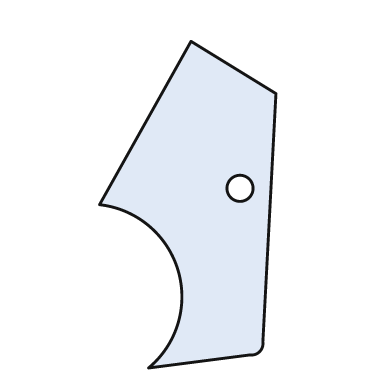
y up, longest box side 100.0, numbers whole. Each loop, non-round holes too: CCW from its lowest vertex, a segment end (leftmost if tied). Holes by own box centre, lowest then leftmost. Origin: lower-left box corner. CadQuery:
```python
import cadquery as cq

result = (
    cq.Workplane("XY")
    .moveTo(15.0, 0.0)
    .lineTo(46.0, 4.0)
    .threePointArc((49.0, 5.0), (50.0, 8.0))
    .lineTo(54.0, 84.0)
    .lineTo(28.0, 100.0)
    .lineTo(0.0, 50.0)
    .threePointArc((24.0, 30.0), (15.0, 0.0))
    .close()
    .moveTo(43.0, 55.0)
    .circle(4.0)
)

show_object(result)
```